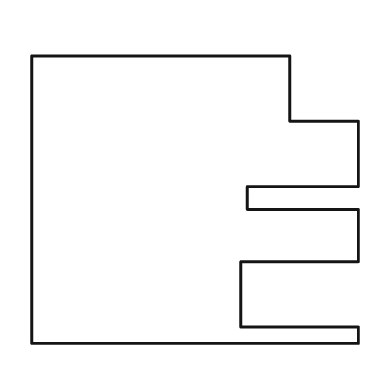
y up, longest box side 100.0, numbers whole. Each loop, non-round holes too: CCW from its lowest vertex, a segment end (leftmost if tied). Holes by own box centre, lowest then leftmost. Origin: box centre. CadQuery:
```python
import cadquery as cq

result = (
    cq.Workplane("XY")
    .moveTo(-50.0, -44.0)
    .lineTo(50.0, -44.0)
    .lineTo(50.0, -39.0)
    .lineTo(14.0, -39.0)
    .lineTo(14.0, -19.0)
    .lineTo(50.0, -19.0)
    .lineTo(50.0, -3.0)
    .lineTo(16.0, -3.0)
    .lineTo(16.0, 4.0)
    .lineTo(50.0, 4.0)
    .lineTo(50.0, 24.0)
    .lineTo(29.0, 24.0)
    .lineTo(29.0, 44.0)
    .lineTo(-50.0, 44.0)
    .close()
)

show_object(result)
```